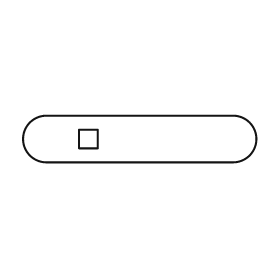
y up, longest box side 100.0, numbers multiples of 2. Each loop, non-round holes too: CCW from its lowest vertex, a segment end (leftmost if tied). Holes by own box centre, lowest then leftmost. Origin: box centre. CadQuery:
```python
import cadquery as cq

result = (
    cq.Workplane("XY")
    .moveTo(-40.0, -10.0)
    .lineTo(40.0, -10.0)
    .threePointArc((50.0, 0.0), (40.0, 10.0))
    .lineTo(-40.0, 10.0)
    .threePointArc((-50.0, 0.0), (-40.0, -10.0))
    .close()
    .moveTo(-26.0, -4.0)
    .lineTo(-18.0, -4.0)
    .lineTo(-18.0, 4.0)
    .lineTo(-26.0, 4.0)
    .close()
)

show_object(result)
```